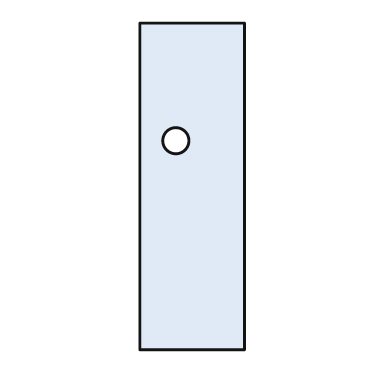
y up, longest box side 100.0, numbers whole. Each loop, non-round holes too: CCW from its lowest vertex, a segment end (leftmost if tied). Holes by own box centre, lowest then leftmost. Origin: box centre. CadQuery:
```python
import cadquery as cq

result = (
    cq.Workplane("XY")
    .moveTo(-16.0, -50.0)
    .lineTo(16.0, -50.0)
    .lineTo(16.0, 50.0)
    .lineTo(-16.0, 50.0)
    .close()
    .moveTo(-5.0, 14.0)
    .circle(4.0)
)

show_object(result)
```